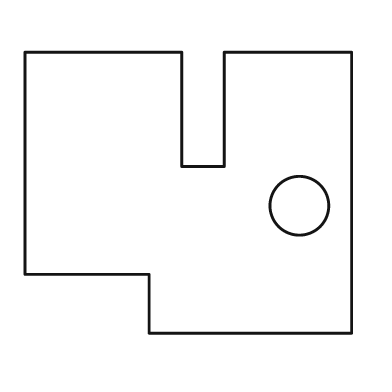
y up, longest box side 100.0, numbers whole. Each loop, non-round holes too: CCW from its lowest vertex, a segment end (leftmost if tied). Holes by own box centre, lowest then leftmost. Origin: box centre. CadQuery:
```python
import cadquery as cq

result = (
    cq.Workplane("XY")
    .moveTo(-12.0, -43.0)
    .lineTo(50.0, -43.0)
    .lineTo(50.0, 43.0)
    .lineTo(11.0, 43.0)
    .lineTo(11.0, 8.0)
    .lineTo(-2.0, 8.0)
    .lineTo(-2.0, 43.0)
    .lineTo(-50.0, 43.0)
    .lineTo(-50.0, -25.0)
    .lineTo(-12.0, -25.0)
    .close()
    .moveTo(34.0, -4.0)
    .circle(9.0)
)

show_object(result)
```